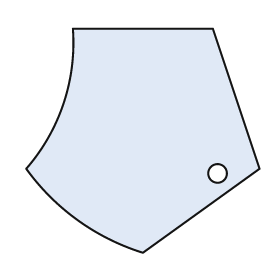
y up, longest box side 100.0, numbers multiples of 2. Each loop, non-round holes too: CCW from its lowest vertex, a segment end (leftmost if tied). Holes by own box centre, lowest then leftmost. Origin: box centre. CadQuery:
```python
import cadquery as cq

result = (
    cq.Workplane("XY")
    .moveTo(0.0, -48.0)
    .lineTo(50.0, -12.0)
    .lineTo(30.0, 48.0)
    .lineTo(-30.0, 48.0)
    .threePointArc((-34.0, 16.0), (-50.0, -12.0))
    .threePointArc((-28.0, -34.0), (0.0, -48.0))
    .close()
    .moveTo(32.0, -14.0)
    .circle(4.0)
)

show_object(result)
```